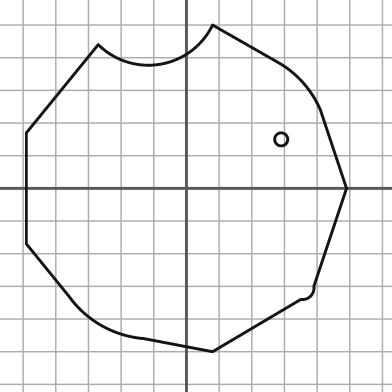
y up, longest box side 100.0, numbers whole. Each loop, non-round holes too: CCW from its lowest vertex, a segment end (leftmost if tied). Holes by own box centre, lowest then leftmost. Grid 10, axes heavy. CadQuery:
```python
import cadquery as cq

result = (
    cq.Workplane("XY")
    .moveTo(8.0, -50.0)
    .lineTo(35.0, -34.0)
    .threePointArc((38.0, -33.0), (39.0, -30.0))
    .lineTo(49.0, 0.0)
    .lineTo(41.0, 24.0)
    .threePointArc((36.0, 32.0), (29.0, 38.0))
    .lineTo(8.0, 50.0)
    .threePointArc((-8.0, 38.0), (-27.0, 44.0))
    .lineTo(-49.0, 17.0)
    .lineTo(-49.0, -17.0)
    .lineTo(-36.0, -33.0)
    .threePointArc((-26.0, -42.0), (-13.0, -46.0))
    .close()
    .moveTo(29.0, 15.0)
    .circle(2.0)
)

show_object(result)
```